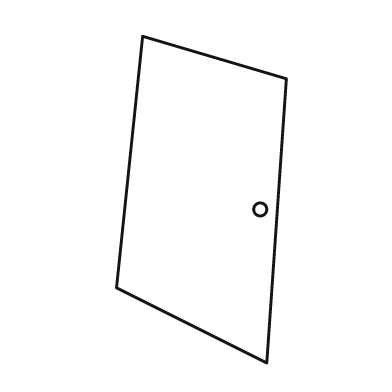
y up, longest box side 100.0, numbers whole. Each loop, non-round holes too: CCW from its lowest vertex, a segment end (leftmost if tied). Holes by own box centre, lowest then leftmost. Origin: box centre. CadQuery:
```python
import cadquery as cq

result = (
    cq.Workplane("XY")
    .moveTo(20.0, -50.0)
    .lineTo(26.0, 37.0)
    .lineTo(-18.0, 50.0)
    .lineTo(-26.0, -27.0)
    .close()
    .moveTo(18.0, -3.0)
    .circle(2.0)
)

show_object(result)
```